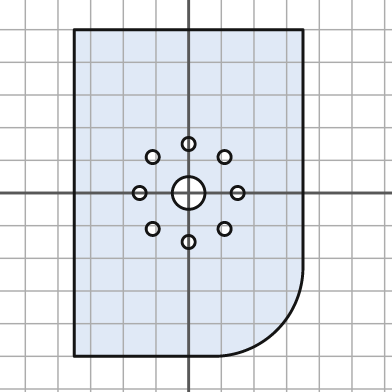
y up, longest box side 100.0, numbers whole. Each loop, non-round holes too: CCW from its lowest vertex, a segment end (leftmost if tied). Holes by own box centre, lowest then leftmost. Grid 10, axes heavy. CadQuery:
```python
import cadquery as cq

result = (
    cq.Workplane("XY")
    .moveTo(-35.0, -50.0)
    .lineTo(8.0, -50.0)
    .threePointArc((27.0, -42.0), (35.0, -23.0))
    .lineTo(35.0, 50.0)
    .lineTo(-35.0, 50.0)
    .close()
    .moveTo(0.0, -15.0)
    .circle(2.0)
    .moveTo(-11.0, -11.0)
    .circle(2.0)
    .moveTo(11.0, -11.0)
    .circle(2.0)
    .moveTo(-15.0, 0.0)
    .circle(2.0)
    .moveTo(0.0, 0.0)
    .circle(5.0)
    .moveTo(15.0, 0.0)
    .circle(2.0)
    .moveTo(-11.0, 11.0)
    .circle(2.0)
    .moveTo(11.0, 11.0)
    .circle(2.0)
    .moveTo(0.0, 15.0)
    .circle(2.0)
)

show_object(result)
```